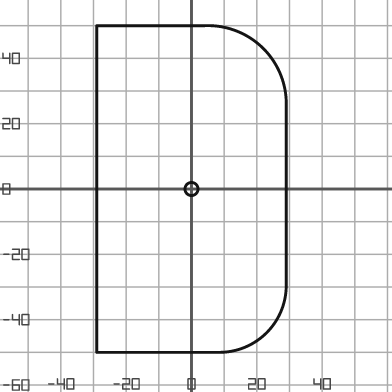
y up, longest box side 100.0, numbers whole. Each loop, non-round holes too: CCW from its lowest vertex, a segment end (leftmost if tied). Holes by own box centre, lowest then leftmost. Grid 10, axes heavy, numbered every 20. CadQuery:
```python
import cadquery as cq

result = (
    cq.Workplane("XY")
    .moveTo(-29.0, -50.0)
    .lineTo(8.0, -50.0)
    .threePointArc((23.0, -44.0), (29.0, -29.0))
    .lineTo(29.0, 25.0)
    .threePointArc((22.0, 43.0), (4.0, 50.0))
    .lineTo(-29.0, 50.0)
    .close()
    .moveTo(0.0, 0.0)
    .circle(2.0)
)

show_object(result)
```